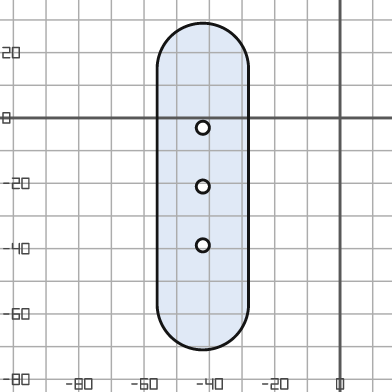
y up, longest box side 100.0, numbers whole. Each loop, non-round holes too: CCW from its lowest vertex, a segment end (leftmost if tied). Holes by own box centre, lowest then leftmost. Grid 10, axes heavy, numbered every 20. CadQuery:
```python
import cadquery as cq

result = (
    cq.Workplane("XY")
    .moveTo(-56.0, -57.0)
    .threePointArc((-42.0, -71.0), (-28.0, -57.0))
    .lineTo(-28.0, 15.0)
    .threePointArc((-42.0, 29.0), (-56.0, 15.0))
    .close()
    .moveTo(-42.0, -39.0)
    .circle(2.0)
    .moveTo(-42.0, -21.0)
    .circle(2.0)
    .moveTo(-42.0, -3.0)
    .circle(2.0)
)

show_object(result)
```